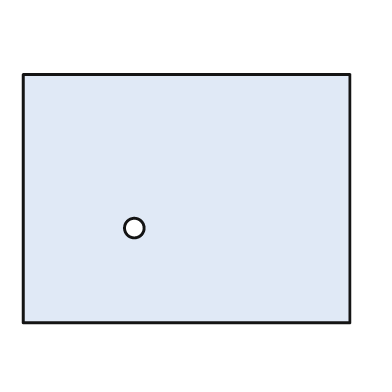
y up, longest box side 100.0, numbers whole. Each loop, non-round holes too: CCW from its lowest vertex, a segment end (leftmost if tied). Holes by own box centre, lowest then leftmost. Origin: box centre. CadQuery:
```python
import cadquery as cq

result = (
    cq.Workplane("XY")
    .moveTo(-50.0, -38.0)
    .lineTo(50.0, -38.0)
    .lineTo(50.0, 38.0)
    .lineTo(-50.0, 38.0)
    .close()
    .moveTo(-16.0, -9.0)
    .circle(3.0)
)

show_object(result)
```